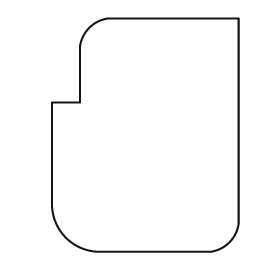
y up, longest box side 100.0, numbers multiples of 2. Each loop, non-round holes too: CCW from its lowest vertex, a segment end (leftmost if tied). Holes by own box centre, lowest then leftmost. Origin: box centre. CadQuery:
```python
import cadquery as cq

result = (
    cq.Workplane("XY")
    .moveTo(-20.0, -50.0)
    .lineTo(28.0, -50.0)
    .threePointArc((36.0, -46.0), (40.0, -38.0))
    .lineTo(40.0, 50.0)
    .lineTo(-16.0, 50.0)
    .threePointArc((-24.0, 46.0), (-28.0, 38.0))
    .lineTo(-28.0, 14.0)
    .lineTo(-40.0, 14.0)
    .lineTo(-40.0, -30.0)
    .threePointArc((-34.0, -44.0), (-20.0, -50.0))
    .close()
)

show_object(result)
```